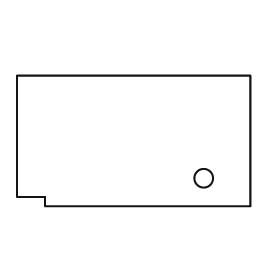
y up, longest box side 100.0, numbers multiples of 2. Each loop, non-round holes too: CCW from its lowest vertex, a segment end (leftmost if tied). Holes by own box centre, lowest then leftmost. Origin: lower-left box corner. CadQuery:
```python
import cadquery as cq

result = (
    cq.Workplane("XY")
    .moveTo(12.0, 0.0)
    .lineTo(100.0, 0.0)
    .lineTo(100.0, 56.0)
    .lineTo(0.0, 56.0)
    .lineTo(0.0, 4.0)
    .lineTo(12.0, 4.0)
    .close()
    .moveTo(80.0, 12.0)
    .circle(4.0)
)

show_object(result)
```